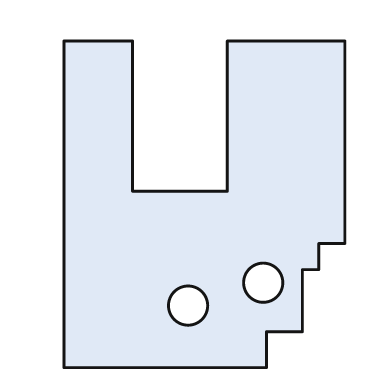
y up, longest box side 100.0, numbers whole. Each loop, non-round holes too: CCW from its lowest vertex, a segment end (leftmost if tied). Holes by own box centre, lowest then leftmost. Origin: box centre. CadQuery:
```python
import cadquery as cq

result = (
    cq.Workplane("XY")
    .moveTo(-43.0, -50.0)
    .lineTo(19.0, -50.0)
    .lineTo(19.0, -39.0)
    .lineTo(30.0, -39.0)
    .lineTo(30.0, -20.0)
    .lineTo(35.0, -20.0)
    .lineTo(35.0, -12.0)
    .lineTo(43.0, -12.0)
    .lineTo(43.0, 50.0)
    .lineTo(7.0, 50.0)
    .lineTo(7.0, 4.0)
    .lineTo(-22.0, 4.0)
    .lineTo(-22.0, 50.0)
    .lineTo(-43.0, 50.0)
    .close()
    .moveTo(-5.0, -31.0)
    .circle(6.0)
    .moveTo(18.0, -24.0)
    .circle(6.0)
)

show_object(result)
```